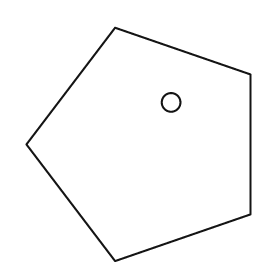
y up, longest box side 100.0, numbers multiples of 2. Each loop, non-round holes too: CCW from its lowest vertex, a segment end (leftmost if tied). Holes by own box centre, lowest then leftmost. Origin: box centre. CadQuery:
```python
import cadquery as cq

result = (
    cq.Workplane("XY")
    .moveTo(-10.0, -50.0)
    .lineTo(48.0, -30.0)
    .lineTo(48.0, 30.0)
    .lineTo(-10.0, 50.0)
    .lineTo(-48.0, 0.0)
    .close()
    .moveTo(14.0, 18.0)
    .circle(4.0)
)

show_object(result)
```